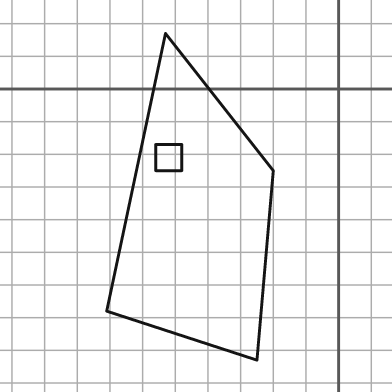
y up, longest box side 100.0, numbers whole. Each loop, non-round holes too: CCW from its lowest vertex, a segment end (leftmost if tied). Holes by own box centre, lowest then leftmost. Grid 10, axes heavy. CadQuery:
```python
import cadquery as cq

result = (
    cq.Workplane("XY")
    .moveTo(-25.0, -83.0)
    .lineTo(-20.0, -25.0)
    .lineTo(-53.0, 17.0)
    .lineTo(-71.0, -68.0)
    .close()
    .moveTo(-56.0, -25.0)
    .lineTo(-48.0, -25.0)
    .lineTo(-48.0, -17.0)
    .lineTo(-56.0, -17.0)
    .close()
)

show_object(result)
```